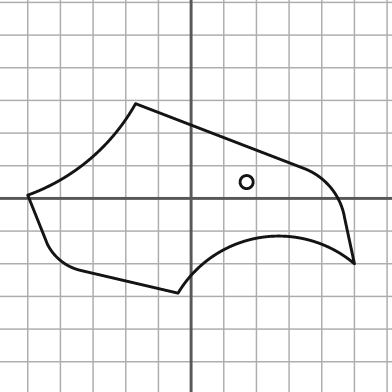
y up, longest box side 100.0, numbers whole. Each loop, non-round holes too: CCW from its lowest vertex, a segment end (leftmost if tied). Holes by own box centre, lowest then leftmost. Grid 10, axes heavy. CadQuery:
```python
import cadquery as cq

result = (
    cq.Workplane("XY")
    .moveTo(-4.0, -29.0)
    .threePointArc((21.0, -12.0), (50.0, -20.0))
    .lineTo(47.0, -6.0)
    .threePointArc((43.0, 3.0), (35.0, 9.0))
    .lineTo(-17.0, 29.0)
    .threePointArc((-31.0, 12.0), (-50.0, 1.0))
    .lineTo(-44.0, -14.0)
    .threePointArc((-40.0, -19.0), (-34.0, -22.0))
    .close()
    .moveTo(17.0, 5.0)
    .circle(2.0)
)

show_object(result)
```